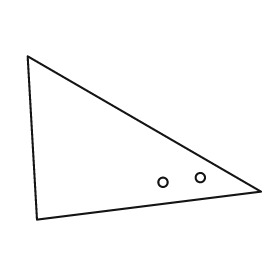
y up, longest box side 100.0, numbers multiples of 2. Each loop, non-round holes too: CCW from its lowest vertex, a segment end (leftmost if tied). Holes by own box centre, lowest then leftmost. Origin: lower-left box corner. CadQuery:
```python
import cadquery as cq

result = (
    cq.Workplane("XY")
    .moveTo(4.0, 0.0)
    .lineTo(100.0, 12.0)
    .lineTo(0.0, 70.0)
    .close()
    .moveTo(58.0, 16.0)
    .circle(2.0)
    .moveTo(74.0, 18.0)
    .circle(2.0)
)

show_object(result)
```